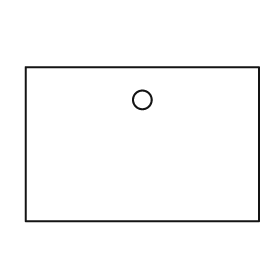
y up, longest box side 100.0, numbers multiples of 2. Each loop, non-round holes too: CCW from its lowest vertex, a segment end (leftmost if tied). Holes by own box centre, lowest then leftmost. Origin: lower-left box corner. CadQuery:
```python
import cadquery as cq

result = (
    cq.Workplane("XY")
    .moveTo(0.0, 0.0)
    .lineTo(100.0, 0.0)
    .lineTo(100.0, 66.0)
    .lineTo(0.0, 66.0)
    .close()
    .moveTo(50.0, 52.0)
    .circle(4.0)
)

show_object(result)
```